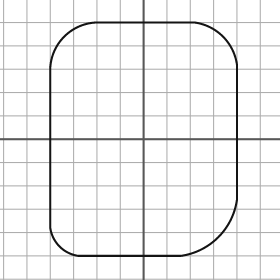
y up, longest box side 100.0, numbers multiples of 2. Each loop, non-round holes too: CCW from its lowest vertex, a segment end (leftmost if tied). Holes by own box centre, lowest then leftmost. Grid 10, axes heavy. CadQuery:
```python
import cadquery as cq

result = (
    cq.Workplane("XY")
    .moveTo(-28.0, -50.0)
    .lineTo(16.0, -50.0)
    .threePointArc((32.0, -42.0), (40.0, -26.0))
    .lineTo(40.0, 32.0)
    .threePointArc((34.0, 44.0), (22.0, 50.0))
    .lineTo(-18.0, 50.0)
    .threePointArc((-34.0, 44.0), (-40.0, 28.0))
    .lineTo(-40.0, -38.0)
    .threePointArc((-36.0, -46.0), (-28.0, -50.0))
    .close()
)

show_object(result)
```